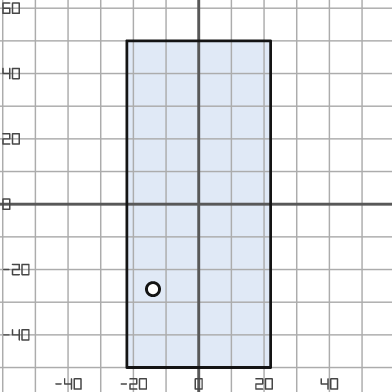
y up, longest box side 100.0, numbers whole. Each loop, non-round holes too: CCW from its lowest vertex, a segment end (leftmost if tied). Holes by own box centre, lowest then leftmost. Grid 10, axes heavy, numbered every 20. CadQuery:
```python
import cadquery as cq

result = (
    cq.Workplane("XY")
    .moveTo(-22.0, -50.0)
    .lineTo(22.0, -50.0)
    .lineTo(22.0, 50.0)
    .lineTo(-22.0, 50.0)
    .close()
    .moveTo(-14.0, -26.0)
    .circle(2.0)
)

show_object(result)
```